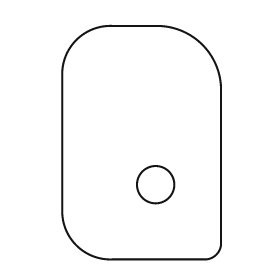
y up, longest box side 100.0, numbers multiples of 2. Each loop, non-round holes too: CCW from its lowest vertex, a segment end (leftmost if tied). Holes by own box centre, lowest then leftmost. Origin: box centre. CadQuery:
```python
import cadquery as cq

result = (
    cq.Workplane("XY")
    .moveTo(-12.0, -50.0)
    .lineTo(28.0, -50.0)
    .threePointArc((32.0, -48.0), (34.0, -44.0))
    .lineTo(34.0, 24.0)
    .threePointArc((26.0, 42.0), (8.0, 50.0))
    .lineTo(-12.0, 50.0)
    .threePointArc((-28.0, 44.0), (-34.0, 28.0))
    .lineTo(-34.0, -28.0)
    .threePointArc((-28.0, -44.0), (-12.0, -50.0))
    .close()
    .moveTo(6.0, -18.0)
    .circle(8.0)
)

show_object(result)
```